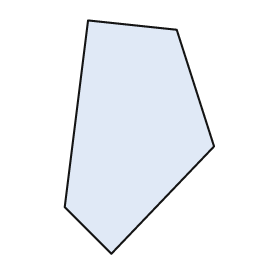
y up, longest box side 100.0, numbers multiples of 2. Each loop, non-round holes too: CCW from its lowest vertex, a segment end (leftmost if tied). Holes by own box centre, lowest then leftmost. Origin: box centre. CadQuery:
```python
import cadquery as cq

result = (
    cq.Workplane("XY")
    .moveTo(-12.0, -50.0)
    .lineTo(32.0, -4.0)
    .lineTo(16.0, 46.0)
    .lineTo(-22.0, 50.0)
    .lineTo(-32.0, -30.0)
    .close()
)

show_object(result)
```